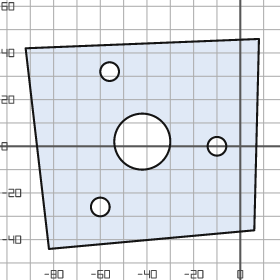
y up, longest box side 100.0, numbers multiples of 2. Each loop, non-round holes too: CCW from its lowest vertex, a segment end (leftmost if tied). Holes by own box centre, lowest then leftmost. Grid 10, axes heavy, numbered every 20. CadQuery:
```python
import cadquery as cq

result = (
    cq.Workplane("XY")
    .moveTo(-82.0, -44.0)
    .lineTo(6.0, -36.0)
    .lineTo(8.0, 46.0)
    .lineTo(-92.0, 42.0)
    .close()
    .moveTo(-60.0, -26.0)
    .circle(4.0)
    .moveTo(-10.0, 0.0)
    .circle(4.0)
    .moveTo(-42.0, 2.0)
    .circle(12.0)
    .moveTo(-56.0, 32.0)
    .circle(4.0)
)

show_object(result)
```